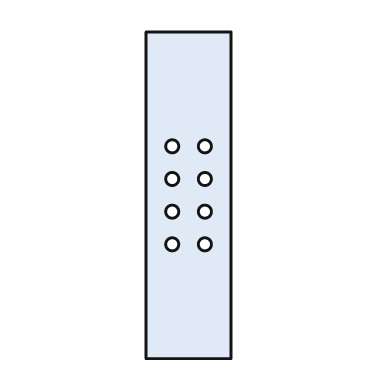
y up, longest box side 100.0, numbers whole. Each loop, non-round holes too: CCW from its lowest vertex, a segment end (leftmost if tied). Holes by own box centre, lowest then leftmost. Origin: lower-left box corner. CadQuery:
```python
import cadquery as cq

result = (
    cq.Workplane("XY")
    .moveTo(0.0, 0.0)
    .lineTo(26.0, 0.0)
    .lineTo(26.0, 100.0)
    .lineTo(0.0, 100.0)
    .close()
    .moveTo(8.0, 35.0)
    .circle(2.0)
    .moveTo(18.0, 35.0)
    .circle(2.0)
    .moveTo(8.0, 45.0)
    .circle(2.0)
    .moveTo(18.0, 45.0)
    .circle(2.0)
    .moveTo(8.0, 55.0)
    .circle(2.0)
    .moveTo(18.0, 55.0)
    .circle(2.0)
    .moveTo(8.0, 65.0)
    .circle(2.0)
    .moveTo(18.0, 65.0)
    .circle(2.0)
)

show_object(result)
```